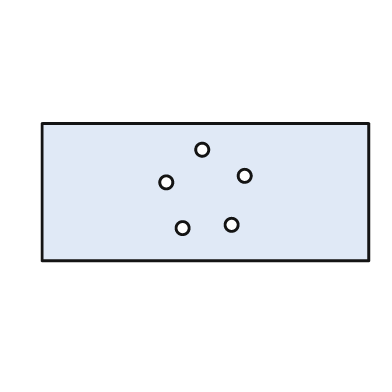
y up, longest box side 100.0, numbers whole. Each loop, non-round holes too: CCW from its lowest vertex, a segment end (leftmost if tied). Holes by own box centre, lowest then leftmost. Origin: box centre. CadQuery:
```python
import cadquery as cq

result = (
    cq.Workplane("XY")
    .moveTo(-50.0, -21.0)
    .lineTo(50.0, -21.0)
    .lineTo(50.0, 21.0)
    .lineTo(-50.0, 21.0)
    .close()
    .moveTo(-7.0, -11.0)
    .circle(2.0)
    .moveTo(8.0, -10.0)
    .circle(2.0)
    .moveTo(-12.0, 3.0)
    .circle(2.0)
    .moveTo(12.0, 5.0)
    .circle(2.0)
    .moveTo(-1.0, 13.0)
    .circle(2.0)
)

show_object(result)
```